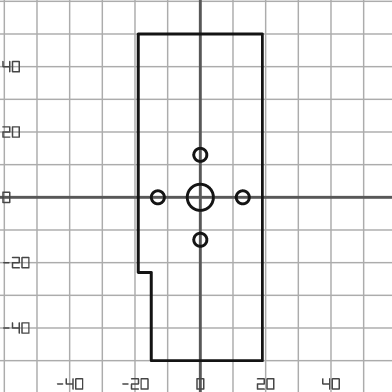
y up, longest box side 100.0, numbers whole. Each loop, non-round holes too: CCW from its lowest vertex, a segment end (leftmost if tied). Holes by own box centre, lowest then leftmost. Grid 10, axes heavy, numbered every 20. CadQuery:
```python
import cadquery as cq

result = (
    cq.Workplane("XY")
    .moveTo(-15.0, -50.0)
    .lineTo(19.0, -50.0)
    .lineTo(19.0, 50.0)
    .lineTo(-19.0, 50.0)
    .lineTo(-19.0, -23.0)
    .lineTo(-15.0, -23.0)
    .close()
    .moveTo(0.0, -13.0)
    .circle(2.0)
    .moveTo(-13.0, 0.0)
    .circle(2.0)
    .moveTo(0.0, 0.0)
    .circle(4.0)
    .moveTo(13.0, 0.0)
    .circle(2.0)
    .moveTo(0.0, 13.0)
    .circle(2.0)
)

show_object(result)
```